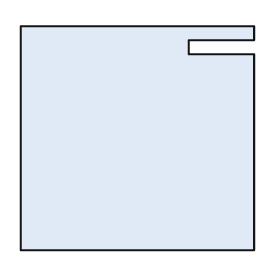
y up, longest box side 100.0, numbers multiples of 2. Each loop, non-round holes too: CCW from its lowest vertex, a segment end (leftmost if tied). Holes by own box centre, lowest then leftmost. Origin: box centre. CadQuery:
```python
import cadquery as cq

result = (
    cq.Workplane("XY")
    .moveTo(-50.0, -48.0)
    .lineTo(50.0, -48.0)
    .lineTo(50.0, 36.0)
    .lineTo(22.0, 36.0)
    .lineTo(22.0, 42.0)
    .lineTo(50.0, 42.0)
    .lineTo(50.0, 48.0)
    .lineTo(-50.0, 48.0)
    .close()
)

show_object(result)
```